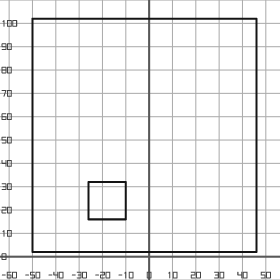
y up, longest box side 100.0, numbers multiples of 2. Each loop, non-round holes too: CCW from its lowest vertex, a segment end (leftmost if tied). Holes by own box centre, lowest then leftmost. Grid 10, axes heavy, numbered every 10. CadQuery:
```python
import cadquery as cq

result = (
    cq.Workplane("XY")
    .moveTo(-50.0, 2.0)
    .lineTo(46.0, 2.0)
    .lineTo(46.0, 102.0)
    .lineTo(-50.0, 102.0)
    .close()
    .moveTo(-26.0, 16.0)
    .lineTo(-10.0, 16.0)
    .lineTo(-10.0, 32.0)
    .lineTo(-26.0, 32.0)
    .close()
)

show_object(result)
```